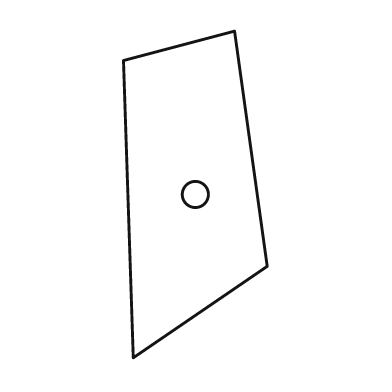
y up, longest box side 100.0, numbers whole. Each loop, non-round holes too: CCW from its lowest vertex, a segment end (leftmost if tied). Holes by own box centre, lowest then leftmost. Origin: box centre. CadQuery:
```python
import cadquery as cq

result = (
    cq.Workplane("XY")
    .moveTo(-19.0, -50.0)
    .lineTo(22.0, -22.0)
    .lineTo(12.0, 50.0)
    .lineTo(-22.0, 41.0)
    .close()
    .moveTo(0.0, 0.0)
    .circle(4.0)
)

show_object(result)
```